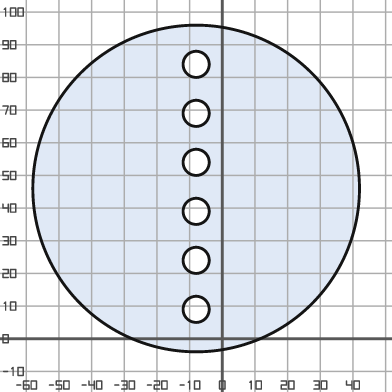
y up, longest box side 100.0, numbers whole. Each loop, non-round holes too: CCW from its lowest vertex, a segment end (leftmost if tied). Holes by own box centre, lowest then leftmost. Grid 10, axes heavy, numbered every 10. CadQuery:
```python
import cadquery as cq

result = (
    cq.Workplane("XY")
    .moveTo(-8.0, 46.0)
    .circle(50.0)
    .moveTo(-8.0, 9.0)
    .circle(4.0)
    .moveTo(-8.0, 24.0)
    .circle(4.0)
    .moveTo(-8.0, 39.0)
    .circle(4.0)
    .moveTo(-8.0, 54.0)
    .circle(4.0)
    .moveTo(-8.0, 69.0)
    .circle(4.0)
    .moveTo(-8.0, 84.0)
    .circle(4.0)
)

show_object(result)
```